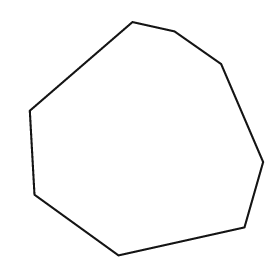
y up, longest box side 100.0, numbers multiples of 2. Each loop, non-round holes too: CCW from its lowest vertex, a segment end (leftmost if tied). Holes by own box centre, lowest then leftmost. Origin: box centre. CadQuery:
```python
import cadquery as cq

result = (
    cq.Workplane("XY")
    .moveTo(-12.0, -50.0)
    .lineTo(42.0, -38.0)
    .lineTo(50.0, -10.0)
    .lineTo(32.0, 32.0)
    .lineTo(12.0, 46.0)
    .lineTo(-6.0, 50.0)
    .lineTo(-50.0, 12.0)
    .lineTo(-48.0, -24.0)
    .close()
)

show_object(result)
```